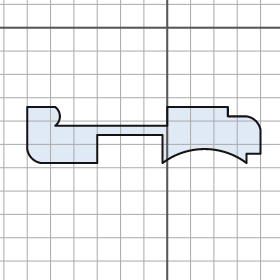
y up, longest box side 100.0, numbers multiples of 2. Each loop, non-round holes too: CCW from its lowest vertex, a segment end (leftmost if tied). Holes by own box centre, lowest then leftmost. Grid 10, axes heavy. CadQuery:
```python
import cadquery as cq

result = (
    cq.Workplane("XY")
    .moveTo(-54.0, -58.0)
    .lineTo(-30.0, -58.0)
    .lineTo(-30.0, -46.0)
    .lineTo(-2.0, -46.0)
    .lineTo(-2.0, -58.0)
    .threePointArc((16.0, -52.0), (34.0, -58.0))
    .lineTo(34.0, -54.0)
    .lineTo(40.0, -54.0)
    .lineTo(40.0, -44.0)
    .threePointArc((38.0, -40.0), (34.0, -38.0))
    .lineTo(26.0, -38.0)
    .lineTo(26.0, -34.0)
    .lineTo(0.0, -34.0)
    .lineTo(0.0, -42.0)
    .lineTo(-48.0, -42.0)
    .threePointArc((-46.0, -38.0), (-48.0, -34.0))
    .lineTo(-60.0, -34.0)
    .lineTo(-60.0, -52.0)
    .threePointArc((-58.0, -56.0), (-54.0, -58.0))
    .close()
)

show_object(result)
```